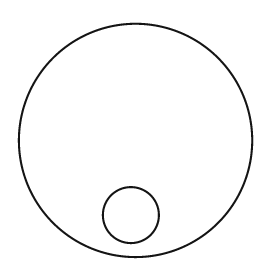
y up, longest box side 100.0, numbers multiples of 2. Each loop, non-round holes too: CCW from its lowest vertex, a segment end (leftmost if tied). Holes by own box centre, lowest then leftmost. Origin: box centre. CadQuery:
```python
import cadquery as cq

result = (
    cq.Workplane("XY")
    .moveTo(0.0, 0.0)
    .circle(50.0)
    .moveTo(-2.0, -32.0)
    .circle(12.0)
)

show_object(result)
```